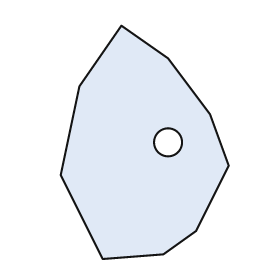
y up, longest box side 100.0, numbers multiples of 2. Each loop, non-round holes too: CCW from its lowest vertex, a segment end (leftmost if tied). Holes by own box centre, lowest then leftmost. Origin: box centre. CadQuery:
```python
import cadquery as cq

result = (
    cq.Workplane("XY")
    .moveTo(-18.0, -50.0)
    .lineTo(8.0, -48.0)
    .lineTo(22.0, -38.0)
    .lineTo(36.0, -10.0)
    .lineTo(28.0, 12.0)
    .lineTo(10.0, 36.0)
    .lineTo(-10.0, 50.0)
    .lineTo(-28.0, 24.0)
    .lineTo(-36.0, -14.0)
    .close()
    .moveTo(10.0, 0.0)
    .circle(6.0)
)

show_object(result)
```